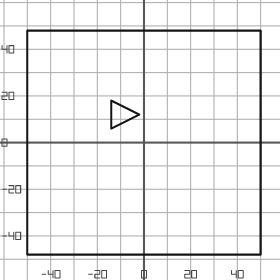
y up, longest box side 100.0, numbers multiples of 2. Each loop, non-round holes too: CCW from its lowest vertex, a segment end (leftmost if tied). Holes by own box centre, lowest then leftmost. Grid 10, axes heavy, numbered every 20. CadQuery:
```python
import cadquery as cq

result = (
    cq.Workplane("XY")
    .moveTo(-50.0, -48.0)
    .lineTo(50.0, -48.0)
    .lineTo(50.0, 48.0)
    .lineTo(-50.0, 48.0)
    .close()
    .moveTo(-14.0, 6.0)
    .lineTo(-2.0, 12.0)
    .lineTo(-14.0, 18.0)
    .close()
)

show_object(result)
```